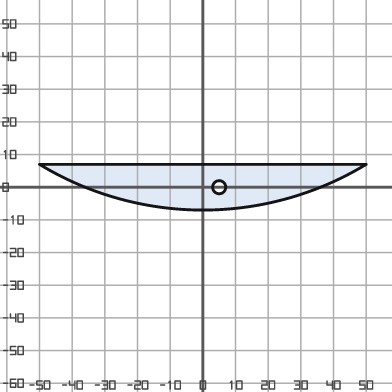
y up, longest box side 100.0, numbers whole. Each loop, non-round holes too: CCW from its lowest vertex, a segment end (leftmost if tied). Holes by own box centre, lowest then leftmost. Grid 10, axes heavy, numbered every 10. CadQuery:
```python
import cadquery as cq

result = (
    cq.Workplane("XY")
    .moveTo(-50.0, 7.0)
    .threePointArc((0.0, -7.0), (50.0, 7.0))
    .close()
    .moveTo(5.0, 0.0)
    .circle(2.0)
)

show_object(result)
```